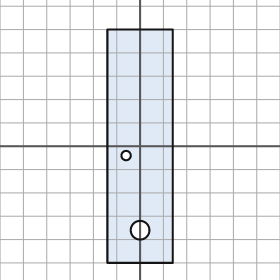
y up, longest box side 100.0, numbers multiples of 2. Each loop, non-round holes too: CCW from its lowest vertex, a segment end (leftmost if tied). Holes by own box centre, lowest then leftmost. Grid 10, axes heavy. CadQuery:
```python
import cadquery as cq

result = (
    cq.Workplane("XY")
    .moveTo(-14.0, -50.0)
    .lineTo(14.0, -50.0)
    .lineTo(14.0, 50.0)
    .lineTo(-14.0, 50.0)
    .close()
    .moveTo(0.0, -36.0)
    .circle(4.0)
    .moveTo(-6.0, -4.0)
    .circle(2.0)
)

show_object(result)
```